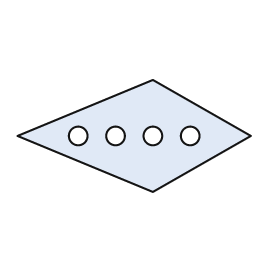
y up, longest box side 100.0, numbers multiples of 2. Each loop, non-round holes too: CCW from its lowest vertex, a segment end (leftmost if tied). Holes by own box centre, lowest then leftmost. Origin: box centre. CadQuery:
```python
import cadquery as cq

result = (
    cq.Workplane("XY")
    .moveTo(8.0, -24.0)
    .lineTo(50.0, 0.0)
    .lineTo(8.0, 24.0)
    .lineTo(-50.0, 0.0)
    .close()
    .moveTo(-24.0, 0.0)
    .circle(4.0)
    .moveTo(-8.0, 0.0)
    .circle(4.0)
    .moveTo(8.0, 0.0)
    .circle(4.0)
    .moveTo(24.0, 0.0)
    .circle(4.0)
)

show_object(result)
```